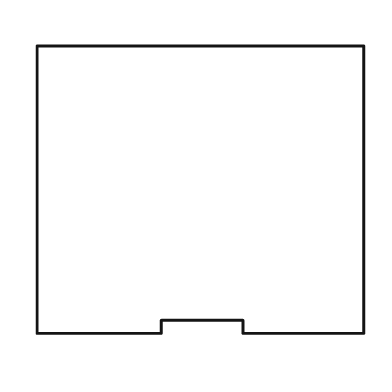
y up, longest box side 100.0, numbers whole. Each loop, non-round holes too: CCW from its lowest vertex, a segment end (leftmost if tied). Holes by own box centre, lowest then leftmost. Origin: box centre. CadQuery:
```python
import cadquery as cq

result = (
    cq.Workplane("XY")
    .moveTo(-50.0, -44.0)
    .lineTo(-12.0, -44.0)
    .lineTo(-12.0, -40.0)
    .lineTo(13.0, -40.0)
    .lineTo(13.0, -44.0)
    .lineTo(50.0, -44.0)
    .lineTo(50.0, 44.0)
    .lineTo(-50.0, 44.0)
    .close()
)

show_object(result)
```